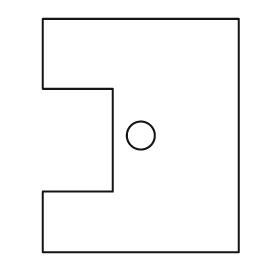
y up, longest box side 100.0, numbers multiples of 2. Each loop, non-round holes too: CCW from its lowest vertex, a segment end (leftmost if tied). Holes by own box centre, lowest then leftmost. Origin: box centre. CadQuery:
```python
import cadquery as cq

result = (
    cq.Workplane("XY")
    .moveTo(-42.0, -50.0)
    .lineTo(42.0, -50.0)
    .lineTo(42.0, 50.0)
    .lineTo(-42.0, 50.0)
    .lineTo(-42.0, 20.0)
    .lineTo(-12.0, 20.0)
    .lineTo(-12.0, -24.0)
    .lineTo(-42.0, -24.0)
    .close()
    .moveTo(0.0, 0.0)
    .circle(6.0)
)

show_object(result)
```